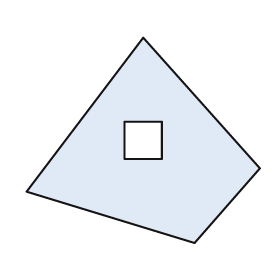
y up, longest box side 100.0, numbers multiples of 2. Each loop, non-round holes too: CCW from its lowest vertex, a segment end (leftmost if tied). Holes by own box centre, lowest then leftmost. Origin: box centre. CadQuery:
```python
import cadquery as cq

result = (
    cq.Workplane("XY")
    .moveTo(22.0, -44.0)
    .lineTo(50.0, -12.0)
    .lineTo(0.0, 44.0)
    .lineTo(-50.0, -22.0)
    .close()
    .moveTo(-8.0, -8.0)
    .lineTo(8.0, -8.0)
    .lineTo(8.0, 8.0)
    .lineTo(-8.0, 8.0)
    .close()
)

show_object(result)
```